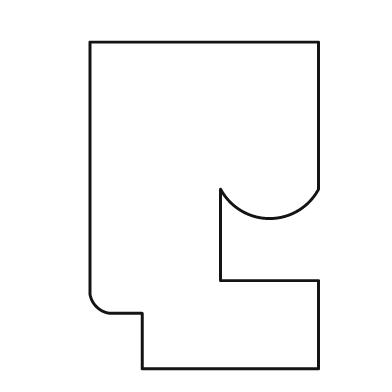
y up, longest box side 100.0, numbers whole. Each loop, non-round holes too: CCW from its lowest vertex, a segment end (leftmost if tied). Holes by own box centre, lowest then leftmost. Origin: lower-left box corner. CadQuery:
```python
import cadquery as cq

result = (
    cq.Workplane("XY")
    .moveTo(16.0, 0.0)
    .lineTo(70.0, 0.0)
    .lineTo(70.0, 27.0)
    .lineTo(40.0, 27.0)
    .lineTo(40.0, 55.0)
    .threePointArc((55.0, 46.0), (70.0, 55.0))
    .lineTo(70.0, 100.0)
    .lineTo(0.0, 100.0)
    .lineTo(0.0, 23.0)
    .threePointArc((2.0, 19.0), (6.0, 17.0))
    .lineTo(16.0, 17.0)
    .close()
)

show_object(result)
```